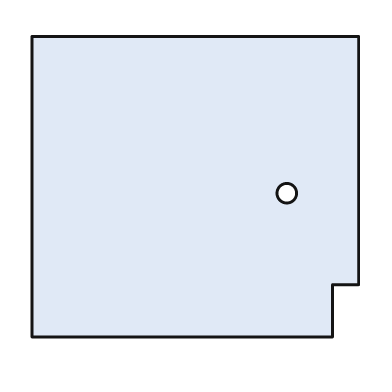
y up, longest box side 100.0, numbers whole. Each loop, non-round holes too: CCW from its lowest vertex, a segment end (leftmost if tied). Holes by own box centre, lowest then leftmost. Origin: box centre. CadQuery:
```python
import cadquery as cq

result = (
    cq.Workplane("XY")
    .moveTo(-50.0, -46.0)
    .lineTo(42.0, -46.0)
    .lineTo(42.0, -30.0)
    .lineTo(50.0, -30.0)
    .lineTo(50.0, 46.0)
    .lineTo(-50.0, 46.0)
    .close()
    .moveTo(28.0, -2.0)
    .circle(3.0)
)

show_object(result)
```